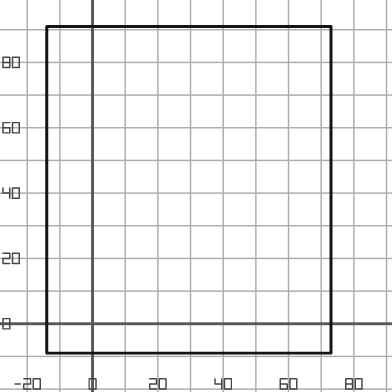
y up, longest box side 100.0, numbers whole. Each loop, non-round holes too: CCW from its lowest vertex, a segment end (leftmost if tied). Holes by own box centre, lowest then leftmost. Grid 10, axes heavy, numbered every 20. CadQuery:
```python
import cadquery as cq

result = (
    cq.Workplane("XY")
    .moveTo(-14.0, -9.0)
    .lineTo(73.0, -9.0)
    .lineTo(73.0, 91.0)
    .lineTo(-14.0, 91.0)
    .close()
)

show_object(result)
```